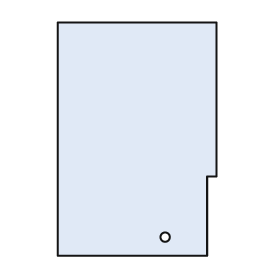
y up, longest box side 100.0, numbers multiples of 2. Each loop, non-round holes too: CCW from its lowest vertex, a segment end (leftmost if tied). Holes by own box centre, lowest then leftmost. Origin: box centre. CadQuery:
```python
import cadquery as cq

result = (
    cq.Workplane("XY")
    .moveTo(-34.0, -50.0)
    .lineTo(30.0, -50.0)
    .lineTo(30.0, -16.0)
    .lineTo(34.0, -16.0)
    .lineTo(34.0, 50.0)
    .lineTo(-34.0, 50.0)
    .close()
    .moveTo(12.0, -42.0)
    .circle(2.0)
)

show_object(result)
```